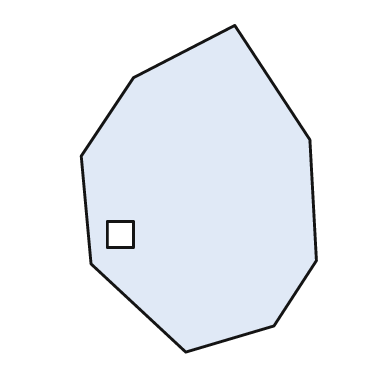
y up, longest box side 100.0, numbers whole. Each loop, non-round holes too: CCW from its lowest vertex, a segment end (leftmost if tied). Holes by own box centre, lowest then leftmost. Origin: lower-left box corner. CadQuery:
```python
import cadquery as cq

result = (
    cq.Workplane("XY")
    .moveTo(32.0, 0.0)
    .lineTo(59.0, 8.0)
    .lineTo(72.0, 28.0)
    .lineTo(70.0, 65.0)
    .lineTo(47.0, 100.0)
    .lineTo(16.0, 84.0)
    .lineTo(0.0, 60.0)
    .lineTo(3.0, 27.0)
    .close()
    .moveTo(8.0, 32.0)
    .lineTo(16.0, 32.0)
    .lineTo(16.0, 40.0)
    .lineTo(8.0, 40.0)
    .close()
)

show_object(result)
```